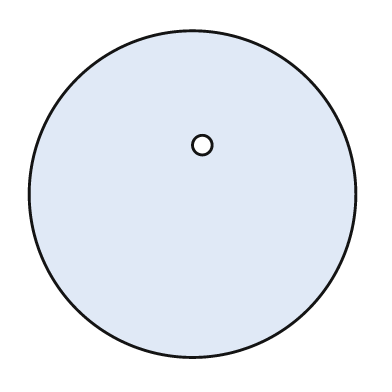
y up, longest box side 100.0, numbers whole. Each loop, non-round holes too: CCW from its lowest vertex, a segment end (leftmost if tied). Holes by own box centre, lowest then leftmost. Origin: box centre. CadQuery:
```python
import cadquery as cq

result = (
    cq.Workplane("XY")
    .moveTo(0.0, 0.0)
    .circle(50.0)
    .moveTo(3.0, 15.0)
    .circle(3.0)
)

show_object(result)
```